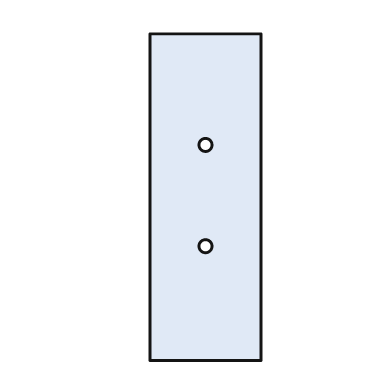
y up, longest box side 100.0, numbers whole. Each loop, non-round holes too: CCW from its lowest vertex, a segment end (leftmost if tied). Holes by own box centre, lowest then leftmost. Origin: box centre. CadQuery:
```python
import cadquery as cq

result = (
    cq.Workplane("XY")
    .moveTo(-17.0, -50.0)
    .lineTo(17.0, -50.0)
    .lineTo(17.0, 50.0)
    .lineTo(-17.0, 50.0)
    .close()
    .moveTo(0.0, -15.0)
    .circle(2.0)
    .moveTo(0.0, 16.0)
    .circle(2.0)
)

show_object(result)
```